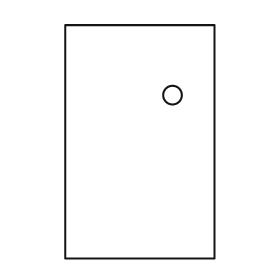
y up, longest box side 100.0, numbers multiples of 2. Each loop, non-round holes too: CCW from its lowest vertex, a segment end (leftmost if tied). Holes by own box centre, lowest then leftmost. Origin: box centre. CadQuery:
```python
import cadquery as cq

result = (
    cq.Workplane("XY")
    .moveTo(-32.0, -50.0)
    .lineTo(32.0, -50.0)
    .lineTo(32.0, 50.0)
    .lineTo(-32.0, 50.0)
    .close()
    .moveTo(14.0, 20.0)
    .circle(4.0)
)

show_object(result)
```